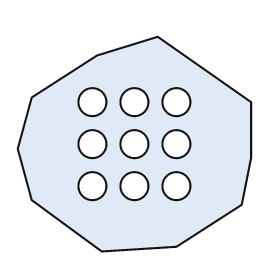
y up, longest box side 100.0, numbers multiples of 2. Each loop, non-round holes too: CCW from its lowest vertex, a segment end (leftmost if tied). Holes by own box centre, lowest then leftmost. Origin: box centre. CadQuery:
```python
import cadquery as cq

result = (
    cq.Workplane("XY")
    .moveTo(-14.0, -46.0)
    .lineTo(18.0, -44.0)
    .lineTo(46.0, -26.0)
    .lineTo(50.0, -6.0)
    .lineTo(50.0, 18.0)
    .lineTo(10.0, 46.0)
    .lineTo(-16.0, 38.0)
    .lineTo(-44.0, 20.0)
    .lineTo(-50.0, -2.0)
    .lineTo(-44.0, -24.0)
    .close()
    .moveTo(-18.0, -18.0)
    .circle(6.0)
    .moveTo(0.0, -18.0)
    .circle(6.0)
    .moveTo(18.0, -18.0)
    .circle(6.0)
    .moveTo(-18.0, 0.0)
    .circle(6.0)
    .moveTo(0.0, 0.0)
    .circle(6.0)
    .moveTo(18.0, 0.0)
    .circle(6.0)
    .moveTo(-18.0, 18.0)
    .circle(6.0)
    .moveTo(0.0, 18.0)
    .circle(6.0)
    .moveTo(18.0, 18.0)
    .circle(6.0)
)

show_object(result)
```